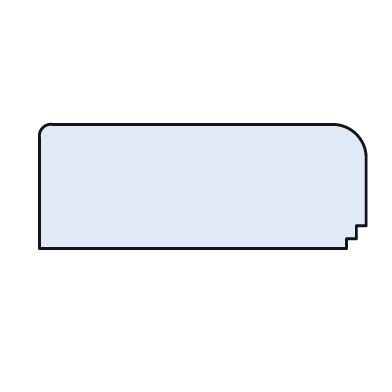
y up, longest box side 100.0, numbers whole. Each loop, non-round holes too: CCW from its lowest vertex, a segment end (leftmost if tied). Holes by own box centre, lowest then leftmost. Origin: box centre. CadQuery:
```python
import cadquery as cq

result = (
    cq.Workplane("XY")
    .moveTo(-50.0, -19.0)
    .lineTo(44.0, -19.0)
    .lineTo(44.0, -16.0)
    .lineTo(47.0, -16.0)
    .lineTo(47.0, -12.0)
    .lineTo(50.0, -12.0)
    .lineTo(50.0, 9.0)
    .threePointArc((47.0, 16.0), (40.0, 19.0))
    .lineTo(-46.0, 19.0)
    .threePointArc((-49.0, 18.0), (-50.0, 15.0))
    .close()
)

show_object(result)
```